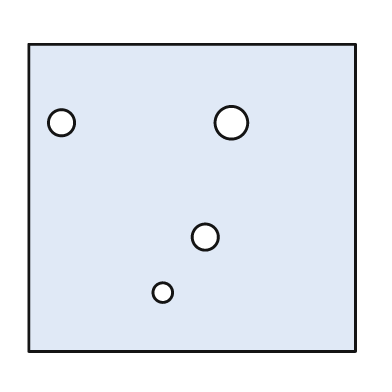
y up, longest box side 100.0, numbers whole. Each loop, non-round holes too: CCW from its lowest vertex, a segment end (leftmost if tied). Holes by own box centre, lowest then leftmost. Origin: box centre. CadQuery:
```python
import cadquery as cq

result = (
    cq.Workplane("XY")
    .moveTo(-50.0, -47.0)
    .lineTo(50.0, -47.0)
    .lineTo(50.0, 47.0)
    .lineTo(-50.0, 47.0)
    .close()
    .moveTo(-9.0, -29.0)
    .circle(3.0)
    .moveTo(4.0, -12.0)
    .circle(4.0)
    .moveTo(-40.0, 23.0)
    .circle(4.0)
    .moveTo(12.0, 23.0)
    .circle(5.0)
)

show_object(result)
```